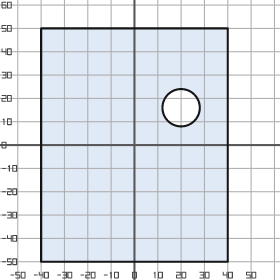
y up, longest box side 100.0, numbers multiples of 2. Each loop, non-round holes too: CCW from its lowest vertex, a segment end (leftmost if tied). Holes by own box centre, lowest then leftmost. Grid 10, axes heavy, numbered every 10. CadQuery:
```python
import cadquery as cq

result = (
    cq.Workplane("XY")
    .moveTo(-40.0, -50.0)
    .lineTo(40.0, -50.0)
    .lineTo(40.0, 50.0)
    .lineTo(-40.0, 50.0)
    .close()
    .moveTo(20.0, 16.0)
    .circle(8.0)
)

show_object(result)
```